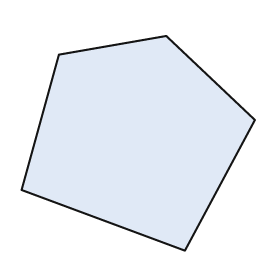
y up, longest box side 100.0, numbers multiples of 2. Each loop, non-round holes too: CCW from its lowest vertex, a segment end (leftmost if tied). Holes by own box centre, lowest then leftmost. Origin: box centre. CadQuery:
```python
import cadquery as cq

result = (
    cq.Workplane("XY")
    .moveTo(20.0, -46.0)
    .lineTo(50.0, 10.0)
    .lineTo(12.0, 46.0)
    .lineTo(-34.0, 38.0)
    .lineTo(-50.0, -20.0)
    .close()
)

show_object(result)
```